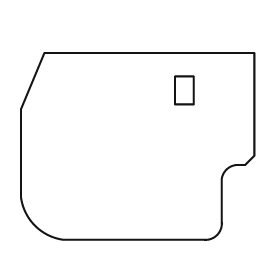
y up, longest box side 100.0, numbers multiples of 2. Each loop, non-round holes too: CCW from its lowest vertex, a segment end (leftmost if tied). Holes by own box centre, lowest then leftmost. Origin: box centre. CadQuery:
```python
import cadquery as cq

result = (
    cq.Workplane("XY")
    .moveTo(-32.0, -40.0)
    .lineTo(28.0, -40.0)
    .threePointArc((34.0, -38.0), (36.0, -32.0))
    .lineTo(36.0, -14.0)
    .threePointArc((38.0, -10.0), (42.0, -8.0))
    .lineTo(46.0, -8.0)
    .lineTo(50.0, -4.0)
    .lineTo(50.0, 40.0)
    .lineTo(-40.0, 40.0)
    .lineTo(-50.0, 16.0)
    .lineTo(-50.0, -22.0)
    .threePointArc((-44.0, -34.0), (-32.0, -40.0))
    .close()
    .moveTo(16.0, 18.0)
    .lineTo(24.0, 18.0)
    .lineTo(24.0, 30.0)
    .lineTo(16.0, 30.0)
    .close()
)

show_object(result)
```